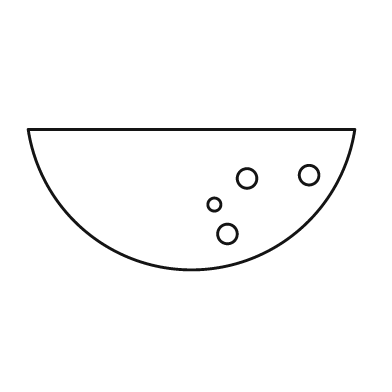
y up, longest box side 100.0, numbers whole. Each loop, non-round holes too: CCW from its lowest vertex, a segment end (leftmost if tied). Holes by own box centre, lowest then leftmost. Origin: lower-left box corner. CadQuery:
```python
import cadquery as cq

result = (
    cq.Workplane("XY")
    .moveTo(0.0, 43.0)
    .threePointArc((50.0, 0.0), (100.0, 43.0))
    .close()
    .moveTo(61.0, 11.0)
    .circle(3.0)
    .moveTo(57.0, 20.0)
    .circle(2.0)
    .moveTo(67.0, 28.0)
    .circle(3.0)
    .moveTo(86.0, 29.0)
    .circle(3.0)
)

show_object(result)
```